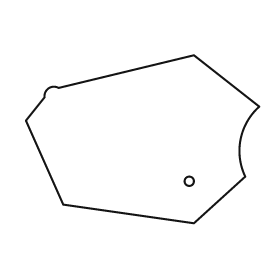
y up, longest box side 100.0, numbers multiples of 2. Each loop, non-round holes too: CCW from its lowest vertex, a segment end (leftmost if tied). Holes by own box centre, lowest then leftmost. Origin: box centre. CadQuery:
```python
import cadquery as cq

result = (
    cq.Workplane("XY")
    .moveTo(22.0, -36.0)
    .lineTo(44.0, -16.0)
    .threePointArc((42.0, 0.0), (50.0, 14.0))
    .lineTo(22.0, 36.0)
    .lineTo(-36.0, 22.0)
    .threePointArc((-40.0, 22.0), (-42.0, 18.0))
    .lineTo(-50.0, 8.0)
    .lineTo(-34.0, -28.0)
    .close()
    .moveTo(20.0, -18.0)
    .circle(2.0)
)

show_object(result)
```